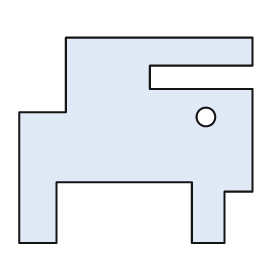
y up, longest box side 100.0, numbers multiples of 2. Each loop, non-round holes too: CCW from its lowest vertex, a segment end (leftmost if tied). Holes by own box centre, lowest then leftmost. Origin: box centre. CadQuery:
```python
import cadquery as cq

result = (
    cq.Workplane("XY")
    .moveTo(-50.0, -44.0)
    .lineTo(-34.0, -44.0)
    .lineTo(-34.0, -18.0)
    .lineTo(24.0, -18.0)
    .lineTo(24.0, -44.0)
    .lineTo(38.0, -44.0)
    .lineTo(38.0, -22.0)
    .lineTo(50.0, -22.0)
    .lineTo(50.0, 22.0)
    .lineTo(6.0, 22.0)
    .lineTo(6.0, 32.0)
    .lineTo(50.0, 32.0)
    .lineTo(50.0, 44.0)
    .lineTo(-30.0, 44.0)
    .lineTo(-30.0, 12.0)
    .lineTo(-50.0, 12.0)
    .close()
    .moveTo(30.0, 10.0)
    .circle(4.0)
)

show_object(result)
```